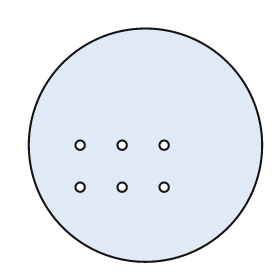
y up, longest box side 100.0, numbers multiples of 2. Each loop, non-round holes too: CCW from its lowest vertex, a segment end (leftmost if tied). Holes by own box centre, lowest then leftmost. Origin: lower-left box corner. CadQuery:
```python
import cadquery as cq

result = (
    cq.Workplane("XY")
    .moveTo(50.0, 50.0)
    .circle(50.0)
    .moveTo(22.0, 32.0)
    .circle(2.0)
    .moveTo(40.0, 32.0)
    .circle(2.0)
    .moveTo(58.0, 32.0)
    .circle(2.0)
    .moveTo(22.0, 50.0)
    .circle(2.0)
    .moveTo(40.0, 50.0)
    .circle(2.0)
    .moveTo(58.0, 50.0)
    .circle(2.0)
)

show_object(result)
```